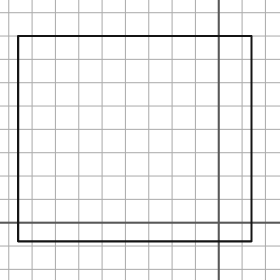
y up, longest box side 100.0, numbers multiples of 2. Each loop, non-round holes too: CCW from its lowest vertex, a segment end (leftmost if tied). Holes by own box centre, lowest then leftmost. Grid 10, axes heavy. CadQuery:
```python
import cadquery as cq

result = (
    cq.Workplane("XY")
    .moveTo(-86.0, -8.0)
    .lineTo(14.0, -8.0)
    .lineTo(14.0, 80.0)
    .lineTo(-86.0, 80.0)
    .close()
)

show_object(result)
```